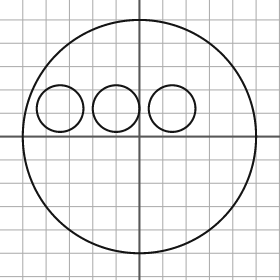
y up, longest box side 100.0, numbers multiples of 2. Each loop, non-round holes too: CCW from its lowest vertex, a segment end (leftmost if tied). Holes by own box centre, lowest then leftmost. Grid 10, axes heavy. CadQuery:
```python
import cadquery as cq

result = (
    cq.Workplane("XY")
    .moveTo(0.0, 0.0)
    .circle(50.0)
    .moveTo(-34.0, 12.0)
    .circle(10.0)
    .moveTo(-10.0, 12.0)
    .circle(10.0)
    .moveTo(14.0, 12.0)
    .circle(10.0)
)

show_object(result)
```